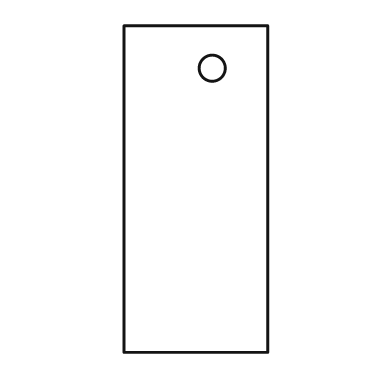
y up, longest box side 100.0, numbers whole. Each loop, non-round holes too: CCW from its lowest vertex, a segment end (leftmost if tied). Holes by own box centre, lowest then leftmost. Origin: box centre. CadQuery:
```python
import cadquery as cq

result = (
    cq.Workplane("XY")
    .moveTo(-22.0, -50.0)
    .lineTo(22.0, -50.0)
    .lineTo(22.0, 50.0)
    .lineTo(-22.0, 50.0)
    .close()
    .moveTo(5.0, 37.0)
    .circle(4.0)
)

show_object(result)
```